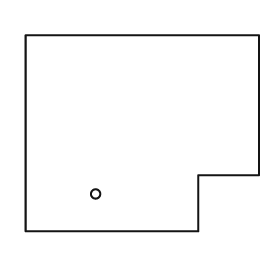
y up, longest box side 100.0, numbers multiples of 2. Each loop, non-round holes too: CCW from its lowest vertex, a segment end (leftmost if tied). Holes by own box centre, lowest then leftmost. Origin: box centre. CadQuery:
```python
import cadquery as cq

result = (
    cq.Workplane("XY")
    .moveTo(-50.0, -42.0)
    .lineTo(24.0, -42.0)
    .lineTo(24.0, -18.0)
    .lineTo(50.0, -18.0)
    .lineTo(50.0, 42.0)
    .lineTo(-50.0, 42.0)
    .close()
    .moveTo(-20.0, -26.0)
    .circle(2.0)
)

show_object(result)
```